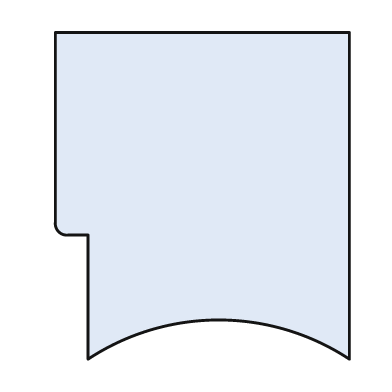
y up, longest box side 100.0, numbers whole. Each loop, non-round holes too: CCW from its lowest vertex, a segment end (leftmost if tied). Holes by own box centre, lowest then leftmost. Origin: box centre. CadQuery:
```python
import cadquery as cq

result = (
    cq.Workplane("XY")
    .moveTo(-35.0, -50.0)
    .threePointArc((5.0, -38.0), (45.0, -50.0))
    .lineTo(45.0, 50.0)
    .lineTo(-45.0, 50.0)
    .lineTo(-45.0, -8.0)
    .threePointArc((-44.0, -11.0), (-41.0, -12.0))
    .lineTo(-35.0, -12.0)
    .close()
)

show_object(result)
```